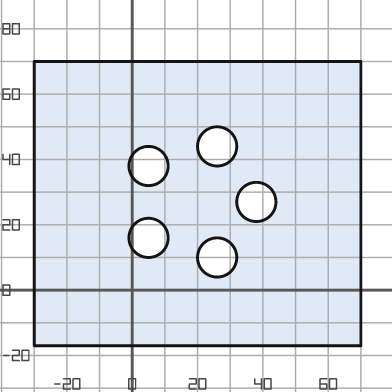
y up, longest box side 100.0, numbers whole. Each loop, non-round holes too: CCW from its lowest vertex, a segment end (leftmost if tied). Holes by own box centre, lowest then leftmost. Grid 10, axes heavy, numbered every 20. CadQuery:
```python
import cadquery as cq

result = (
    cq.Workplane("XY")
    .moveTo(-30.0, -17.0)
    .lineTo(70.0, -17.0)
    .lineTo(70.0, 70.0)
    .lineTo(-30.0, 70.0)
    .close()
    .moveTo(26.0, 10.0)
    .circle(6.0)
    .moveTo(5.0, 16.0)
    .circle(6.0)
    .moveTo(38.0, 27.0)
    .circle(6.0)
    .moveTo(5.0, 38.0)
    .circle(6.0)
    .moveTo(26.0, 44.0)
    .circle(6.0)
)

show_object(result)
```